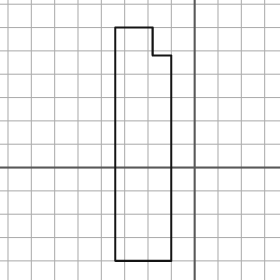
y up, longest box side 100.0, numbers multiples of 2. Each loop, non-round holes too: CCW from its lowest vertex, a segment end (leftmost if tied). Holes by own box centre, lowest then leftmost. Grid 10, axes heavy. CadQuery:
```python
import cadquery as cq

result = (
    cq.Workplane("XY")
    .moveTo(-34.0, -40.0)
    .lineTo(-10.0, -40.0)
    .lineTo(-10.0, 48.0)
    .lineTo(-18.0, 48.0)
    .lineTo(-18.0, 60.0)
    .lineTo(-34.0, 60.0)
    .close()
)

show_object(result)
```